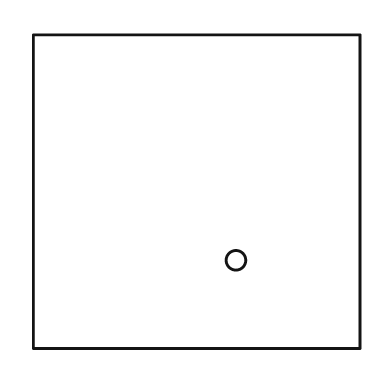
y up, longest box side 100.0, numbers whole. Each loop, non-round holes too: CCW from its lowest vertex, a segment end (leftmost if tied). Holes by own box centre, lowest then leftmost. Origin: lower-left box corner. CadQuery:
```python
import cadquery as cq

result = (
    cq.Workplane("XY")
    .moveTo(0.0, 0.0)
    .lineTo(100.0, 0.0)
    .lineTo(100.0, 96.0)
    .lineTo(0.0, 96.0)
    .close()
    .moveTo(62.0, 27.0)
    .circle(3.0)
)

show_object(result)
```